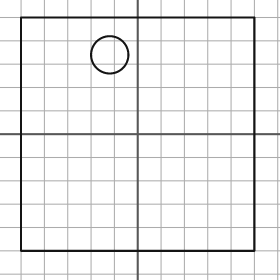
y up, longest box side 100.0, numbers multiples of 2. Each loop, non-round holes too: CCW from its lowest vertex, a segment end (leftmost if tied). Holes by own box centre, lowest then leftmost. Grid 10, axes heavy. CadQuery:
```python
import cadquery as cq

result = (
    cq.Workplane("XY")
    .moveTo(-50.0, -50.0)
    .lineTo(50.0, -50.0)
    .lineTo(50.0, 50.0)
    .lineTo(-50.0, 50.0)
    .close()
    .moveTo(-12.0, 34.0)
    .circle(8.0)
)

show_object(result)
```